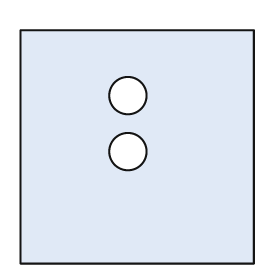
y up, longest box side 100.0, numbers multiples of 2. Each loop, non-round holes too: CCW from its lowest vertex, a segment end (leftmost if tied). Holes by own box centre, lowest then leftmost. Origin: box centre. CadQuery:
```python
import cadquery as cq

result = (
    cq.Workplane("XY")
    .moveTo(-50.0, -50.0)
    .lineTo(50.0, -50.0)
    .lineTo(50.0, 50.0)
    .lineTo(-50.0, 50.0)
    .close()
    .moveTo(-4.0, -2.0)
    .circle(8.0)
    .moveTo(-4.0, 22.0)
    .circle(8.0)
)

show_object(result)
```